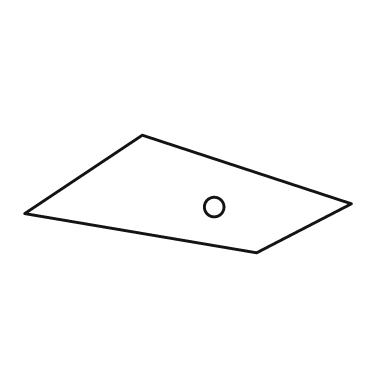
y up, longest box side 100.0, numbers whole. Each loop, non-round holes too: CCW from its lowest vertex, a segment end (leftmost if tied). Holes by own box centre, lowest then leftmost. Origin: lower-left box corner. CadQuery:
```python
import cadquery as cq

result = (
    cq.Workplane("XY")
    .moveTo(71.0, 0.0)
    .lineTo(100.0, 15.0)
    .lineTo(36.0, 36.0)
    .lineTo(0.0, 12.0)
    .close()
    .moveTo(58.0, 14.0)
    .circle(3.0)
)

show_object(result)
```